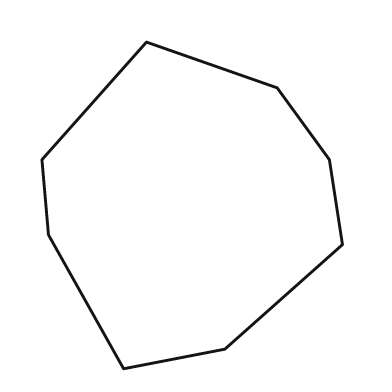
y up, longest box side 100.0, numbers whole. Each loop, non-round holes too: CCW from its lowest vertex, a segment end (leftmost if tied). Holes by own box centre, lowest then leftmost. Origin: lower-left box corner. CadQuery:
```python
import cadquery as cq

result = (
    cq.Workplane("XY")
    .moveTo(25.0, 0.0)
    .lineTo(56.0, 6.0)
    .lineTo(92.0, 38.0)
    .lineTo(88.0, 64.0)
    .lineTo(72.0, 86.0)
    .lineTo(32.0, 100.0)
    .lineTo(0.0, 64.0)
    .lineTo(2.0, 41.0)
    .close()
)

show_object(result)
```